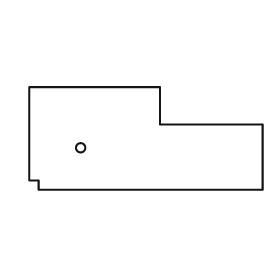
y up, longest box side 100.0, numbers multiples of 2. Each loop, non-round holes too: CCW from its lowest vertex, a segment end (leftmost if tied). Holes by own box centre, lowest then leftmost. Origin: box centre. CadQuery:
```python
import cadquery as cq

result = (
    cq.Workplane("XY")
    .moveTo(-46.0, -22.0)
    .lineTo(50.0, -22.0)
    .lineTo(50.0, 6.0)
    .lineTo(6.0, 6.0)
    .lineTo(6.0, 22.0)
    .lineTo(-50.0, 22.0)
    .lineTo(-50.0, -18.0)
    .lineTo(-46.0, -18.0)
    .close()
    .moveTo(-28.0, -4.0)
    .circle(2.0)
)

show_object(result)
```